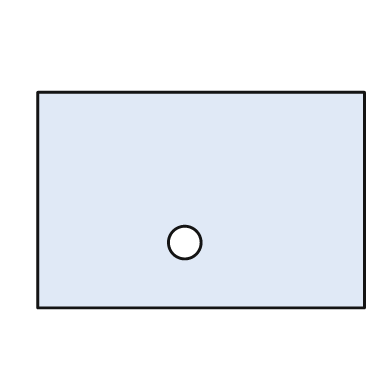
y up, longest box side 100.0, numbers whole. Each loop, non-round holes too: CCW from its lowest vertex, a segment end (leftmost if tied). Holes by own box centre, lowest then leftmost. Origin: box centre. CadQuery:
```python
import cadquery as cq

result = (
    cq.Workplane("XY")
    .moveTo(-50.0, -33.0)
    .lineTo(50.0, -33.0)
    .lineTo(50.0, 33.0)
    .lineTo(-50.0, 33.0)
    .close()
    .moveTo(-5.0, -13.0)
    .circle(5.0)
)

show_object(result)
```